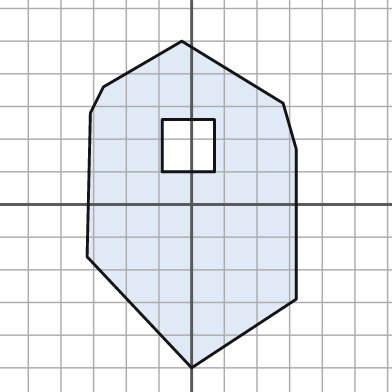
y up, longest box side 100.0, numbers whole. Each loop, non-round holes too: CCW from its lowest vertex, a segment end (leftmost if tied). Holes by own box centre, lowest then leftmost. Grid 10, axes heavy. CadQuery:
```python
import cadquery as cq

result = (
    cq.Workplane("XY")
    .moveTo(0.0, -50.0)
    .lineTo(32.0, -29.0)
    .lineTo(32.0, 17.0)
    .lineTo(28.0, 31.0)
    .lineTo(-3.0, 50.0)
    .lineTo(-27.0, 36.0)
    .lineTo(-31.0, 28.0)
    .lineTo(-32.0, -16.0)
    .close()
    .moveTo(-9.0, 10.0)
    .lineTo(7.0, 10.0)
    .lineTo(7.0, 26.0)
    .lineTo(-9.0, 26.0)
    .close()
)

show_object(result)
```